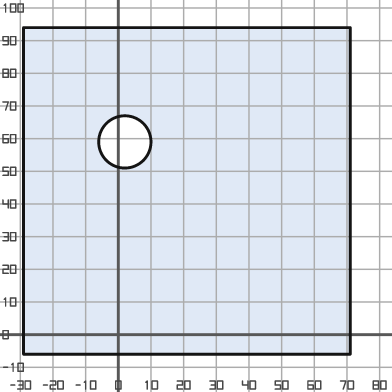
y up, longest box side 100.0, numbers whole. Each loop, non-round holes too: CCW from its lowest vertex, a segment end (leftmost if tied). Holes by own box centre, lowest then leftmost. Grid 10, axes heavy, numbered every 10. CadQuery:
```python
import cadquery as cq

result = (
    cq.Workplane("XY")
    .moveTo(-29.0, -6.0)
    .lineTo(71.0, -6.0)
    .lineTo(71.0, 94.0)
    .lineTo(-29.0, 94.0)
    .close()
    .moveTo(2.0, 59.0)
    .circle(8.0)
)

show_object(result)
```